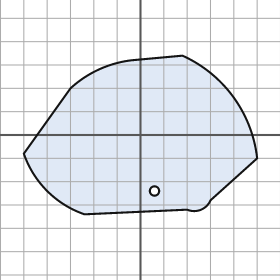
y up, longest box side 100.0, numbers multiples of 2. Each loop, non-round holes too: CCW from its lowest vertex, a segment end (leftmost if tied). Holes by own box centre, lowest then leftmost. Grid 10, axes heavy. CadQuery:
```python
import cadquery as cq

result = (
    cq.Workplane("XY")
    .moveTo(-24.0, -34.0)
    .lineTo(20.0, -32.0)
    .threePointArc((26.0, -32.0), (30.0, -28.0))
    .lineTo(50.0, -10.0)
    .threePointArc((40.0, 16.0), (18.0, 34.0))
    .lineTo(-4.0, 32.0)
    .threePointArc((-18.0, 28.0), (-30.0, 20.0))
    .lineTo(-50.0, -8.0)
    .threePointArc((-40.0, -24.0), (-24.0, -34.0))
    .close()
    .moveTo(6.0, -24.0)
    .circle(2.0)
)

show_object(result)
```